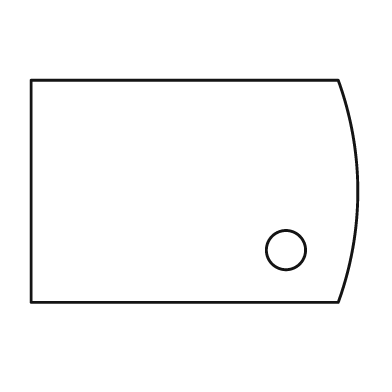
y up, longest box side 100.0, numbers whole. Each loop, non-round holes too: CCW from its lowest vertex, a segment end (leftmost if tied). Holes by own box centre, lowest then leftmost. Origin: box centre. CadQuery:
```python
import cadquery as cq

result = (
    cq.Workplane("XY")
    .moveTo(-50.0, -34.0)
    .lineTo(44.0, -34.0)
    .threePointArc((50.0, 0.0), (44.0, 34.0))
    .lineTo(-50.0, 34.0)
    .close()
    .moveTo(28.0, -18.0)
    .circle(6.0)
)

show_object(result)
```